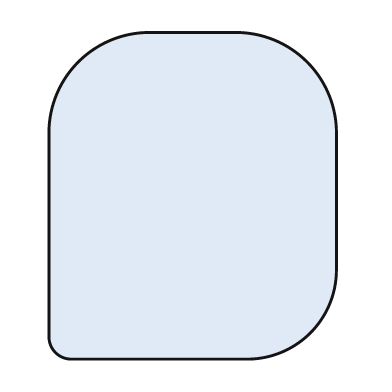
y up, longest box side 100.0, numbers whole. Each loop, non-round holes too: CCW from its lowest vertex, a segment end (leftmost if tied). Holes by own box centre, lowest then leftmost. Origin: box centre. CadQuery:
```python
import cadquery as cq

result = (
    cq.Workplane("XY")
    .moveTo(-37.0, -50.0)
    .lineTo(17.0, -50.0)
    .threePointArc((36.0, -42.0), (44.0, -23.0))
    .lineTo(44.0, 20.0)
    .threePointArc((35.0, 41.0), (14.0, 50.0))
    .lineTo(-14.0, 50.0)
    .threePointArc((-35.0, 41.0), (-44.0, 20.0))
    .lineTo(-44.0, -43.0)
    .threePointArc((-42.0, -48.0), (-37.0, -50.0))
    .close()
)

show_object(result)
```